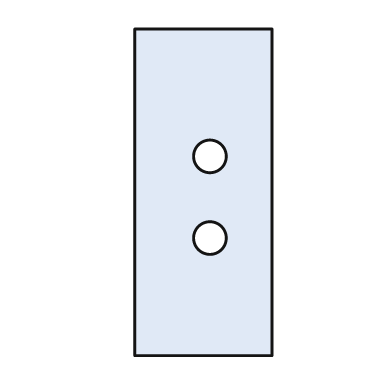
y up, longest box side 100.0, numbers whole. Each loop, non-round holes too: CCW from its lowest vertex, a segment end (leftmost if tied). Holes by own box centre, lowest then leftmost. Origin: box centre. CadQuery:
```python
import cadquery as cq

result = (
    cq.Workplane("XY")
    .moveTo(-21.0, -50.0)
    .lineTo(21.0, -50.0)
    .lineTo(21.0, 50.0)
    .lineTo(-21.0, 50.0)
    .close()
    .moveTo(2.0, -14.0)
    .circle(5.0)
    .moveTo(2.0, 11.0)
    .circle(5.0)
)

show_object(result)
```